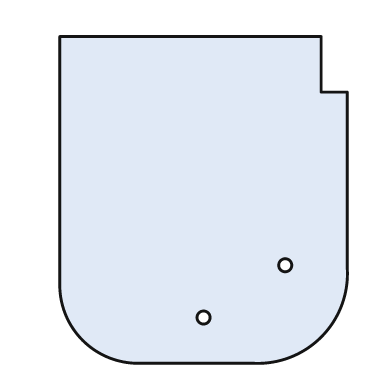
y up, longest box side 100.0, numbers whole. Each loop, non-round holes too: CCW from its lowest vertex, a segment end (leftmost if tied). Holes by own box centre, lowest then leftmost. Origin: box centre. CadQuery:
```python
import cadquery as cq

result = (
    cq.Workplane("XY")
    .moveTo(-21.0, -50.0)
    .lineTo(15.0, -50.0)
    .threePointArc((36.0, -42.0), (44.0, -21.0))
    .lineTo(44.0, 33.0)
    .lineTo(36.0, 33.0)
    .lineTo(36.0, 50.0)
    .lineTo(-44.0, 50.0)
    .lineTo(-44.0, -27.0)
    .threePointArc((-37.0, -43.0), (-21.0, -50.0))
    .close()
    .moveTo(0.0, -36.0)
    .circle(2.0)
    .moveTo(25.0, -20.0)
    .circle(2.0)
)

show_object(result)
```